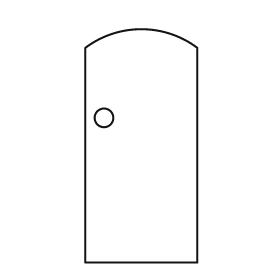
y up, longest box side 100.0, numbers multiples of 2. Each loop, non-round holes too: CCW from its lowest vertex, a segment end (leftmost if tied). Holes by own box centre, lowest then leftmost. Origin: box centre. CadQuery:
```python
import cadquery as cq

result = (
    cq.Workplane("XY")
    .moveTo(-24.0, -50.0)
    .lineTo(24.0, -50.0)
    .lineTo(24.0, 42.0)
    .threePointArc((0.0, 50.0), (-24.0, 42.0))
    .close()
    .moveTo(-16.0, 12.0)
    .circle(4.0)
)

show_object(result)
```